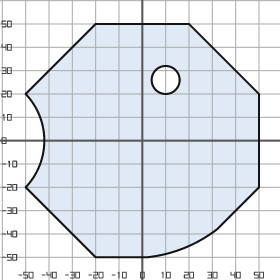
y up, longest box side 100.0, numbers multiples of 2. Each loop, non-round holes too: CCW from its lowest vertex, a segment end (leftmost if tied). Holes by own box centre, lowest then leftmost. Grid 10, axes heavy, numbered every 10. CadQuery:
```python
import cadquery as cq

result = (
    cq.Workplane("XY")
    .moveTo(-20.0, -50.0)
    .lineTo(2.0, -50.0)
    .threePointArc((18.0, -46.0), (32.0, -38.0))
    .lineTo(50.0, -20.0)
    .lineTo(50.0, 20.0)
    .lineTo(20.0, 50.0)
    .lineTo(-20.0, 50.0)
    .lineTo(-50.0, 20.0)
    .threePointArc((-42.0, 0.0), (-50.0, -20.0))
    .close()
    .moveTo(10.0, 26.0)
    .circle(6.0)
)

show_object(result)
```